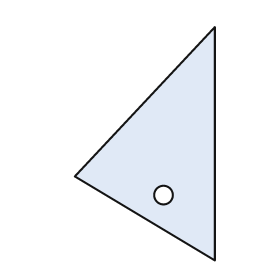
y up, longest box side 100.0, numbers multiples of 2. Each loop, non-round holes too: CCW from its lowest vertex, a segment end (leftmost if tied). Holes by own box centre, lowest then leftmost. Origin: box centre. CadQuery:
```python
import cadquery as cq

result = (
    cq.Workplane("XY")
    .moveTo(30.0, -50.0)
    .lineTo(30.0, 50.0)
    .lineTo(-30.0, -14.0)
    .close()
    .moveTo(8.0, -22.0)
    .circle(4.0)
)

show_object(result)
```